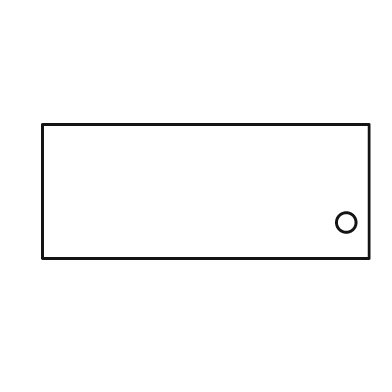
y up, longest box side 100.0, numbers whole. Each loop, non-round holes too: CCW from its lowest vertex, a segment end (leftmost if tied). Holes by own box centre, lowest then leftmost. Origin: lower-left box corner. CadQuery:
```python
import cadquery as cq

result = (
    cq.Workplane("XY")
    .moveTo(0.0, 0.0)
    .lineTo(100.0, 0.0)
    .lineTo(100.0, 41.0)
    .lineTo(0.0, 41.0)
    .close()
    .moveTo(93.0, 11.0)
    .circle(3.0)
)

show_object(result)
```